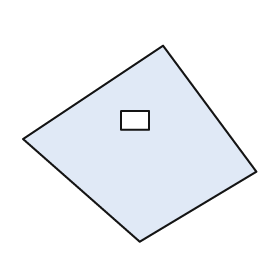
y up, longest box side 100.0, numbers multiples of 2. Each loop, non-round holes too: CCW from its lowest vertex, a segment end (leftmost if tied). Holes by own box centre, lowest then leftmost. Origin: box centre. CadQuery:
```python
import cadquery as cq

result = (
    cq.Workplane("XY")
    .moveTo(0.0, -42.0)
    .lineTo(50.0, -12.0)
    .lineTo(10.0, 42.0)
    .lineTo(-50.0, 2.0)
    .close()
    .moveTo(-8.0, 6.0)
    .lineTo(4.0, 6.0)
    .lineTo(4.0, 14.0)
    .lineTo(-8.0, 14.0)
    .close()
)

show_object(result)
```